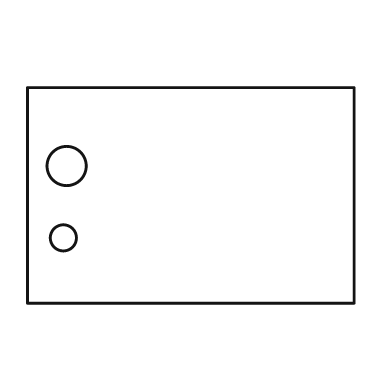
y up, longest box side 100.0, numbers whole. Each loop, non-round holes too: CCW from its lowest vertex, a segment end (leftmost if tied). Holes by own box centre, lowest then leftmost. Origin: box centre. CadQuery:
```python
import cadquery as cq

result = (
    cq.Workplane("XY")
    .moveTo(-50.0, -33.0)
    .lineTo(50.0, -33.0)
    .lineTo(50.0, 33.0)
    .lineTo(-50.0, 33.0)
    .close()
    .moveTo(-39.0, -13.0)
    .circle(4.0)
    .moveTo(-38.0, 9.0)
    .circle(6.0)
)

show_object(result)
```